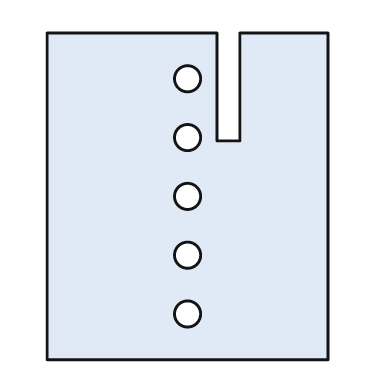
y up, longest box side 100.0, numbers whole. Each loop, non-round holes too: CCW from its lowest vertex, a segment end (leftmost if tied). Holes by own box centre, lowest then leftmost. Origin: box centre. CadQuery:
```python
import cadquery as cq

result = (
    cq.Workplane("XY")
    .moveTo(-43.0, -50.0)
    .lineTo(43.0, -50.0)
    .lineTo(43.0, 50.0)
    .lineTo(16.0, 50.0)
    .lineTo(16.0, 17.0)
    .lineTo(9.0, 17.0)
    .lineTo(9.0, 50.0)
    .lineTo(-43.0, 50.0)
    .close()
    .moveTo(0.0, -36.0)
    .circle(4.0)
    .moveTo(0.0, -18.0)
    .circle(4.0)
    .moveTo(0.0, 0.0)
    .circle(4.0)
    .moveTo(0.0, 18.0)
    .circle(4.0)
    .moveTo(0.0, 36.0)
    .circle(4.0)
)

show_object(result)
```